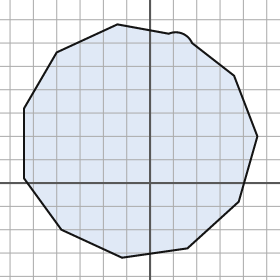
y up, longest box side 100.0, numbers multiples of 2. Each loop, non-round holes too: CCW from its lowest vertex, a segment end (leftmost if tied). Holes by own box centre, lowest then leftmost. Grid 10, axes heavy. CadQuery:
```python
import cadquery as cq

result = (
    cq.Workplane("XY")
    .moveTo(-12.0, -32.0)
    .lineTo(16.0, -28.0)
    .lineTo(38.0, -8.0)
    .lineTo(46.0, 20.0)
    .lineTo(36.0, 46.0)
    .lineTo(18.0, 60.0)
    .threePointArc((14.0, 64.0), (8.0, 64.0))
    .lineTo(-14.0, 68.0)
    .lineTo(-40.0, 56.0)
    .lineTo(-54.0, 32.0)
    .lineTo(-54.0, 2.0)
    .lineTo(-38.0, -20.0)
    .close()
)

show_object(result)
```